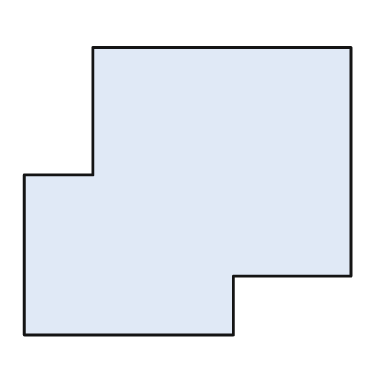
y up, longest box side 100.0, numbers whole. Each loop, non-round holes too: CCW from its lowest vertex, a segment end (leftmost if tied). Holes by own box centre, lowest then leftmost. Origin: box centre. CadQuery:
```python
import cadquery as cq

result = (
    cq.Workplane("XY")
    .moveTo(-50.0, -44.0)
    .lineTo(14.0, -44.0)
    .lineTo(14.0, -26.0)
    .lineTo(50.0, -26.0)
    .lineTo(50.0, 44.0)
    .lineTo(-29.0, 44.0)
    .lineTo(-29.0, 5.0)
    .lineTo(-50.0, 5.0)
    .close()
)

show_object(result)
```